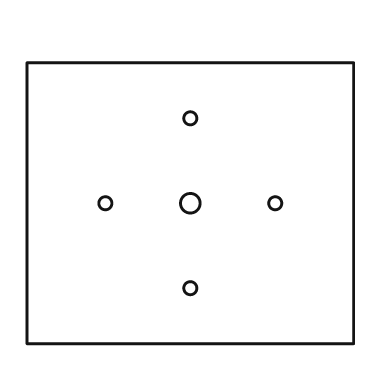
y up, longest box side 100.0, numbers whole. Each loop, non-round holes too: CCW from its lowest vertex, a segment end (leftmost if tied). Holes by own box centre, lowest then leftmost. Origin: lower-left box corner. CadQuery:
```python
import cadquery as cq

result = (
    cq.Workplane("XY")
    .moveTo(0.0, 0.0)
    .lineTo(100.0, 0.0)
    .lineTo(100.0, 86.0)
    .lineTo(0.0, 86.0)
    .close()
    .moveTo(50.0, 17.0)
    .circle(2.0)
    .moveTo(24.0, 43.0)
    .circle(2.0)
    .moveTo(50.0, 43.0)
    .circle(3.0)
    .moveTo(76.0, 43.0)
    .circle(2.0)
    .moveTo(50.0, 69.0)
    .circle(2.0)
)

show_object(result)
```